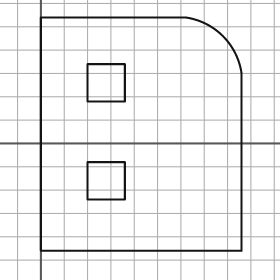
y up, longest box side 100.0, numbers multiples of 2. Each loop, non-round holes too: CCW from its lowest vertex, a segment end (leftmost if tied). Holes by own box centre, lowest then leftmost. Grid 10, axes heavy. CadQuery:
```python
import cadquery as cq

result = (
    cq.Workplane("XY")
    .moveTo(0.0, -46.0)
    .lineTo(86.0, -46.0)
    .lineTo(86.0, 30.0)
    .threePointArc((78.0, 46.0), (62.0, 54.0))
    .lineTo(0.0, 54.0)
    .close()
    .moveTo(20.0, -24.0)
    .lineTo(36.0, -24.0)
    .lineTo(36.0, -8.0)
    .lineTo(20.0, -8.0)
    .close()
    .moveTo(20.0, 18.0)
    .lineTo(36.0, 18.0)
    .lineTo(36.0, 34.0)
    .lineTo(20.0, 34.0)
    .close()
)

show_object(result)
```